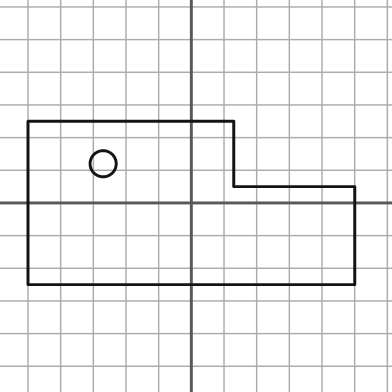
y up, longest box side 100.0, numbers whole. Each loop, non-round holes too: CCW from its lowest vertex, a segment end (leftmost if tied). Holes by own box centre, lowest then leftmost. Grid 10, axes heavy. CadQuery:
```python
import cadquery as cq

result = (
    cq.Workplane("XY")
    .moveTo(-50.0, -25.0)
    .lineTo(50.0, -25.0)
    .lineTo(50.0, 5.0)
    .lineTo(13.0, 5.0)
    .lineTo(13.0, 25.0)
    .lineTo(-50.0, 25.0)
    .close()
    .moveTo(-27.0, 12.0)
    .circle(4.0)
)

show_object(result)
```